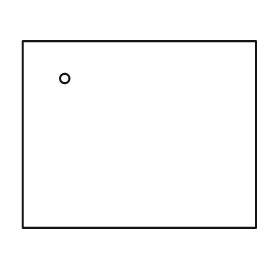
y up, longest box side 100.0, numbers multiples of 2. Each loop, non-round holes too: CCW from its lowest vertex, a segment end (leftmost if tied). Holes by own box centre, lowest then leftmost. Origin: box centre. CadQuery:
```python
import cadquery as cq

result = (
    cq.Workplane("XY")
    .moveTo(-50.0, -40.0)
    .lineTo(50.0, -40.0)
    .lineTo(50.0, 40.0)
    .lineTo(-50.0, 40.0)
    .close()
    .moveTo(-32.0, 24.0)
    .circle(2.0)
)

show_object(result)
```